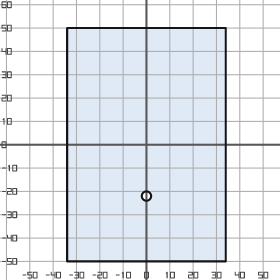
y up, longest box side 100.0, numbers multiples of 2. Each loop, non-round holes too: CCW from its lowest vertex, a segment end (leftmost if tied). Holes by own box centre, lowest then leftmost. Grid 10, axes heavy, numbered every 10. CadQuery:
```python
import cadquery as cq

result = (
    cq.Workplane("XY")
    .moveTo(-34.0, -50.0)
    .lineTo(34.0, -50.0)
    .lineTo(34.0, 50.0)
    .lineTo(-34.0, 50.0)
    .close()
    .moveTo(0.0, -22.0)
    .circle(2.0)
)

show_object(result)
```